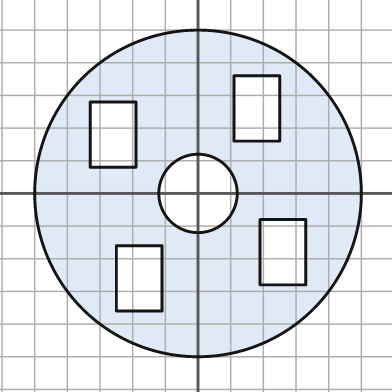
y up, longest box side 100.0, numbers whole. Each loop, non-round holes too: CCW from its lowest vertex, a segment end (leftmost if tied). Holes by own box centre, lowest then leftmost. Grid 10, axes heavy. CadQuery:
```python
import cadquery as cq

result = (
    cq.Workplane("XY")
    .moveTo(0.0, 0.0)
    .circle(50.0)
    .moveTo(-25.0, -36.0)
    .lineTo(-11.0, -36.0)
    .lineTo(-11.0, -16.0)
    .lineTo(-25.0, -16.0)
    .close()
    .moveTo(19.0, -28.0)
    .lineTo(33.0, -28.0)
    .lineTo(33.0, -8.0)
    .lineTo(19.0, -8.0)
    .close()
    .moveTo(0.0, 0.0)
    .circle(12.0)
    .moveTo(-33.0, 8.0)
    .lineTo(-19.0, 8.0)
    .lineTo(-19.0, 28.0)
    .lineTo(-33.0, 28.0)
    .close()
    .moveTo(11.0, 16.0)
    .lineTo(25.0, 16.0)
    .lineTo(25.0, 36.0)
    .lineTo(11.0, 36.0)
    .close()
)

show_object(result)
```